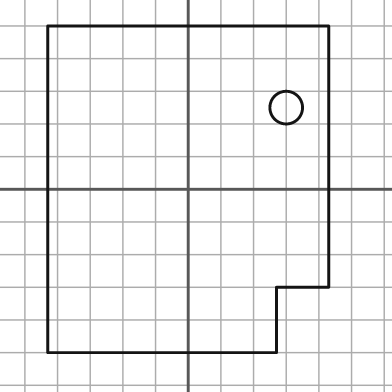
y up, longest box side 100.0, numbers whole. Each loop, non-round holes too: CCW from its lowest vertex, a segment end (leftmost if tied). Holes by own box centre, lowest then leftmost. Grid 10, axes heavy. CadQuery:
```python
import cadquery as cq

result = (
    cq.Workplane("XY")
    .moveTo(-43.0, -50.0)
    .lineTo(27.0, -50.0)
    .lineTo(27.0, -30.0)
    .lineTo(43.0, -30.0)
    .lineTo(43.0, 50.0)
    .lineTo(-43.0, 50.0)
    .close()
    .moveTo(30.0, 25.0)
    .circle(5.0)
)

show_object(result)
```